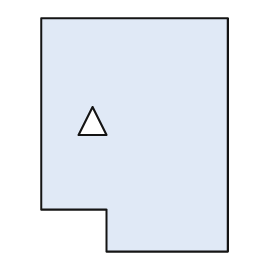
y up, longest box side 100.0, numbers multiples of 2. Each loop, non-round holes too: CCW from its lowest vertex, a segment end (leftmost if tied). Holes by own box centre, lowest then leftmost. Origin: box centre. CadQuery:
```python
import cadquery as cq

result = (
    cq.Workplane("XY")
    .moveTo(-12.0, -50.0)
    .lineTo(40.0, -50.0)
    .lineTo(40.0, 50.0)
    .lineTo(-40.0, 50.0)
    .lineTo(-40.0, -32.0)
    .lineTo(-12.0, -32.0)
    .close()
    .moveTo(-24.0, 0.0)
    .lineTo(-12.0, 0.0)
    .lineTo(-18.0, 12.0)
    .close()
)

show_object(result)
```